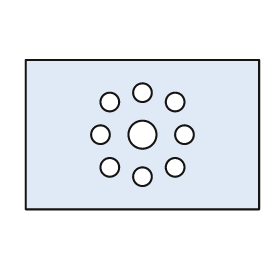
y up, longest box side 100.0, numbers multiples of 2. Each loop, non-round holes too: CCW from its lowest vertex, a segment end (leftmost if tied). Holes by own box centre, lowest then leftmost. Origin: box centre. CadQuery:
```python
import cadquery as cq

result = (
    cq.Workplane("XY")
    .moveTo(-50.0, -32.0)
    .lineTo(50.0, -32.0)
    .lineTo(50.0, 32.0)
    .lineTo(-50.0, 32.0)
    .close()
    .moveTo(0.0, -18.0)
    .circle(4.0)
    .moveTo(-14.0, -14.0)
    .circle(4.0)
    .moveTo(14.0, -14.0)
    .circle(4.0)
    .moveTo(-18.0, 0.0)
    .circle(4.0)
    .moveTo(0.0, 0.0)
    .circle(6.0)
    .moveTo(18.0, 0.0)
    .circle(4.0)
    .moveTo(-14.0, 14.0)
    .circle(4.0)
    .moveTo(14.0, 14.0)
    .circle(4.0)
    .moveTo(0.0, 18.0)
    .circle(4.0)
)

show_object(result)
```